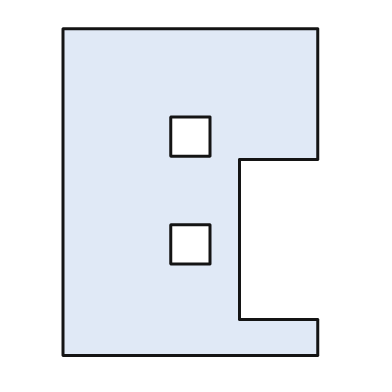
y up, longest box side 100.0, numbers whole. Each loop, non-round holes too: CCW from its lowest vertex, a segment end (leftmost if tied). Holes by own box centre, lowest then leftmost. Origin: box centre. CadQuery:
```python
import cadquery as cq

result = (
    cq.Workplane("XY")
    .moveTo(-39.0, -50.0)
    .lineTo(39.0, -50.0)
    .lineTo(39.0, -39.0)
    .lineTo(15.0, -39.0)
    .lineTo(15.0, 10.0)
    .lineTo(39.0, 10.0)
    .lineTo(39.0, 50.0)
    .lineTo(-39.0, 50.0)
    .close()
    .moveTo(-6.0, -22.0)
    .lineTo(6.0, -22.0)
    .lineTo(6.0, -10.0)
    .lineTo(-6.0, -10.0)
    .close()
    .moveTo(-6.0, 11.0)
    .lineTo(6.0, 11.0)
    .lineTo(6.0, 23.0)
    .lineTo(-6.0, 23.0)
    .close()
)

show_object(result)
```